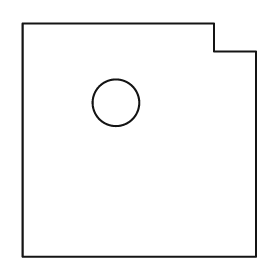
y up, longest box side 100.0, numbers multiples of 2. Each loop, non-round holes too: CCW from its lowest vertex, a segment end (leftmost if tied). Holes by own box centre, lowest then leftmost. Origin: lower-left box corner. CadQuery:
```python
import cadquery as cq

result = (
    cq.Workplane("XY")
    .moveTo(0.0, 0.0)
    .lineTo(100.0, 0.0)
    .lineTo(100.0, 88.0)
    .lineTo(82.0, 88.0)
    .lineTo(82.0, 100.0)
    .lineTo(0.0, 100.0)
    .close()
    .moveTo(40.0, 66.0)
    .circle(10.0)
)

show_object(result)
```